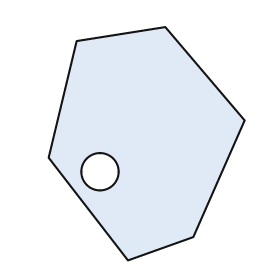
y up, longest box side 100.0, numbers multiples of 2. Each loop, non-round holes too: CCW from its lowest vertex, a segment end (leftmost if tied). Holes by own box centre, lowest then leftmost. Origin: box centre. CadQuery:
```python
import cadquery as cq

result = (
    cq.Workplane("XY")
    .moveTo(-8.0, -50.0)
    .lineTo(20.0, -40.0)
    .lineTo(42.0, 10.0)
    .lineTo(8.0, 50.0)
    .lineTo(-30.0, 44.0)
    .lineTo(-42.0, -6.0)
    .close()
    .moveTo(-20.0, -12.0)
    .circle(8.0)
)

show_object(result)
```